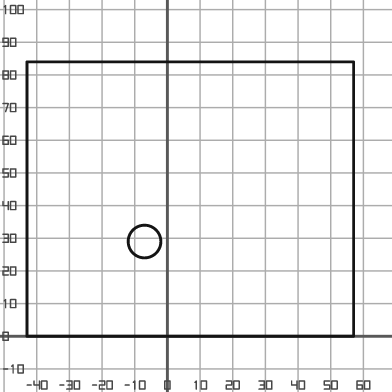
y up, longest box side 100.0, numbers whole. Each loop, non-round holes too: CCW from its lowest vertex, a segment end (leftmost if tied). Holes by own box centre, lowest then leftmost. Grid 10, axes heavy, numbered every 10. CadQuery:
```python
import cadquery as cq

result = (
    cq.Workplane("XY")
    .moveTo(-43.0, 0.0)
    .lineTo(57.0, 0.0)
    .lineTo(57.0, 84.0)
    .lineTo(-43.0, 84.0)
    .close()
    .moveTo(-7.0, 29.0)
    .circle(5.0)
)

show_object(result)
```